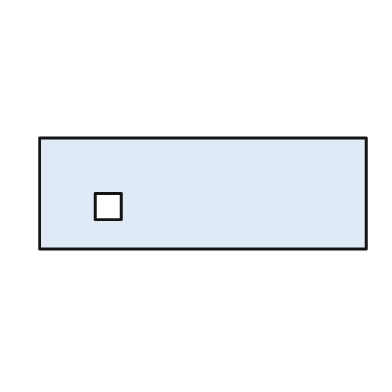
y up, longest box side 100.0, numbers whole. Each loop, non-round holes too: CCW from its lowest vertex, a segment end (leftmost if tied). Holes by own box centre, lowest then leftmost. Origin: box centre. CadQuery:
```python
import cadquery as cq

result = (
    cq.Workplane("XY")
    .moveTo(-50.0, -17.0)
    .lineTo(50.0, -17.0)
    .lineTo(50.0, 17.0)
    .lineTo(-50.0, 17.0)
    .close()
    .moveTo(-33.0, -8.0)
    .lineTo(-25.0, -8.0)
    .lineTo(-25.0, 0.0)
    .lineTo(-33.0, 0.0)
    .close()
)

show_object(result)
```